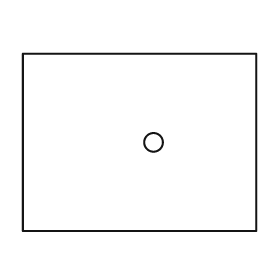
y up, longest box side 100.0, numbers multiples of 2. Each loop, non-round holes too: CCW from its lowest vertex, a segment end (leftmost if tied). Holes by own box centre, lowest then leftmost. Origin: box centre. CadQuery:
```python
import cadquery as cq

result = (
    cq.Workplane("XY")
    .moveTo(-50.0, -38.0)
    .lineTo(50.0, -38.0)
    .lineTo(50.0, 38.0)
    .lineTo(-50.0, 38.0)
    .close()
    .moveTo(6.0, 0.0)
    .circle(4.0)
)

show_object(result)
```